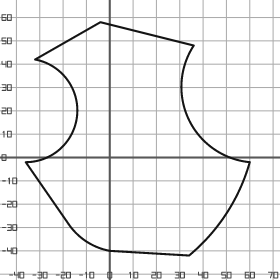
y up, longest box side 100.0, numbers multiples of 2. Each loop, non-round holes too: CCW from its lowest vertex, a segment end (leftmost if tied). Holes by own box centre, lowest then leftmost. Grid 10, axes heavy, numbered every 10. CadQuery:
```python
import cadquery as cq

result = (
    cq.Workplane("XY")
    .moveTo(34.0, -42.0)
    .threePointArc((50.0, -24.0), (60.0, -2.0))
    .threePointArc((34.0, 16.0), (36.0, 48.0))
    .lineTo(-4.0, 58.0)
    .lineTo(-32.0, 42.0)
    .threePointArc((-14.0, 18.0), (-36.0, -2.0))
    .lineTo(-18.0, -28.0)
    .threePointArc((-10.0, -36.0), (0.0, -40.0))
    .close()
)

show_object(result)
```